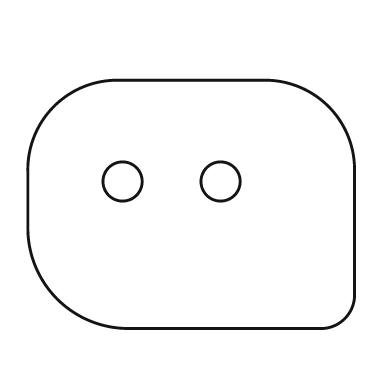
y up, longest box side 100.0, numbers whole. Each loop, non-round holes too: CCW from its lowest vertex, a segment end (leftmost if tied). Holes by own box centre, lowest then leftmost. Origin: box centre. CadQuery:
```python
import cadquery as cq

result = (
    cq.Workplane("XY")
    .moveTo(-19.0, -38.0)
    .lineTo(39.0, -38.0)
    .threePointArc((47.0, -35.0), (50.0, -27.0))
    .lineTo(50.0, 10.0)
    .threePointArc((42.0, 30.0), (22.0, 38.0))
    .lineTo(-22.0, 38.0)
    .threePointArc((-42.0, 30.0), (-50.0, 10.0))
    .lineTo(-50.0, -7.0)
    .threePointArc((-41.0, -29.0), (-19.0, -38.0))
    .close()
    .moveTo(-21.0, 7.0)
    .circle(6.0)
    .moveTo(9.0, 7.0)
    .circle(6.0)
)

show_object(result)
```